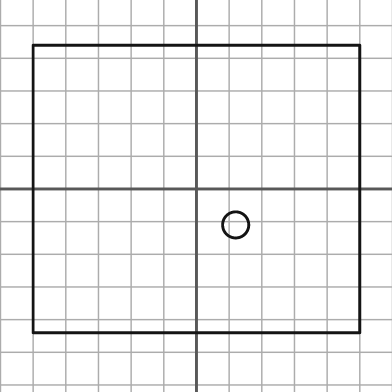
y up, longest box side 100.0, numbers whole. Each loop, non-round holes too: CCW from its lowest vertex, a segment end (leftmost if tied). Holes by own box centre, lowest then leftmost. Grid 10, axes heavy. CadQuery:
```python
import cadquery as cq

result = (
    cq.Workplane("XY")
    .moveTo(-50.0, -44.0)
    .lineTo(50.0, -44.0)
    .lineTo(50.0, 44.0)
    .lineTo(-50.0, 44.0)
    .close()
    .moveTo(12.0, -11.0)
    .circle(4.0)
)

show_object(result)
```